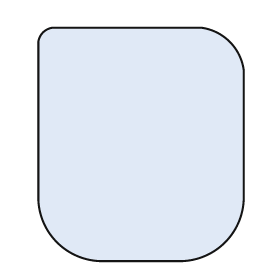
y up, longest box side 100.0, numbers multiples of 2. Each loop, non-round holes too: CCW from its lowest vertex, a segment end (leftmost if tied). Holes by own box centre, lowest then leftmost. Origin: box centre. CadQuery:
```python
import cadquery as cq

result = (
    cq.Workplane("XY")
    .moveTo(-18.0, -50.0)
    .lineTo(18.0, -50.0)
    .threePointArc((36.0, -42.0), (44.0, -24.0))
    .lineTo(44.0, 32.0)
    .threePointArc((38.0, 44.0), (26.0, 50.0))
    .lineTo(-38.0, 50.0)
    .threePointArc((-42.0, 48.0), (-44.0, 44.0))
    .lineTo(-44.0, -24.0)
    .threePointArc((-36.0, -42.0), (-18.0, -50.0))
    .close()
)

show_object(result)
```